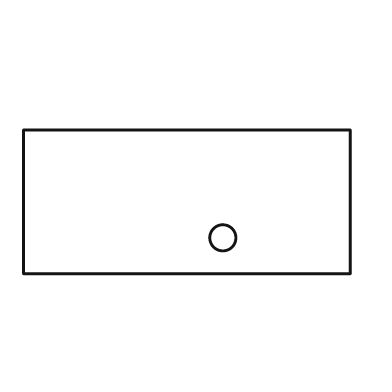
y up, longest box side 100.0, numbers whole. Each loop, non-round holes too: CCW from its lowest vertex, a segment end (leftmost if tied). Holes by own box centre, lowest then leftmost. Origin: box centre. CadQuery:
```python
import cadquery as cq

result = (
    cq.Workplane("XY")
    .moveTo(-50.0, -22.0)
    .lineTo(50.0, -22.0)
    .lineTo(50.0, 22.0)
    .lineTo(-50.0, 22.0)
    .close()
    .moveTo(11.0, -11.0)
    .circle(4.0)
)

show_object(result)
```